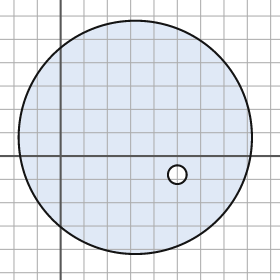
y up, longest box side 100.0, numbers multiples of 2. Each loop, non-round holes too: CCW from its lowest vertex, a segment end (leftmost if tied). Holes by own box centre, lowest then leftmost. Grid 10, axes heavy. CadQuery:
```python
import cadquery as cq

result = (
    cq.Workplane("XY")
    .moveTo(32.0, 8.0)
    .circle(50.0)
    .moveTo(50.0, -8.0)
    .circle(4.0)
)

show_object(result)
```